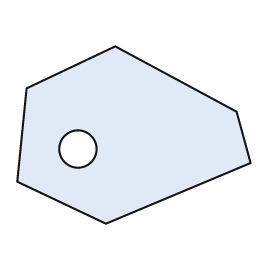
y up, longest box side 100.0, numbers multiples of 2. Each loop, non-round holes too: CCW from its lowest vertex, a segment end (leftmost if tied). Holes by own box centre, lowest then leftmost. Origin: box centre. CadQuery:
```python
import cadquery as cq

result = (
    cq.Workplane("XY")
    .moveTo(-12.0, -38.0)
    .lineTo(50.0, -12.0)
    .lineTo(44.0, 10.0)
    .lineTo(-8.0, 38.0)
    .lineTo(-46.0, 20.0)
    .lineTo(-50.0, -20.0)
    .close()
    .moveTo(-24.0, -6.0)
    .circle(8.0)
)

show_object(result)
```